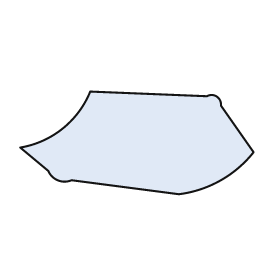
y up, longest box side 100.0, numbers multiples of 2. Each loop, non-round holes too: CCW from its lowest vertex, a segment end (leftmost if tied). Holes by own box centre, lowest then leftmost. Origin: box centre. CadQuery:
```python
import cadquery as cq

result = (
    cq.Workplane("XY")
    .moveTo(18.0, -22.0)
    .threePointArc((36.0, -16.0), (50.0, -4.0))
    .lineTo(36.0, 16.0)
    .threePointArc((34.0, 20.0), (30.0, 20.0))
    .lineTo(-20.0, 22.0)
    .threePointArc((-32.0, 6.0), (-50.0, -2.0))
    .lineTo(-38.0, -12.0)
    .threePointArc((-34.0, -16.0), (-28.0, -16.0))
    .close()
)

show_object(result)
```